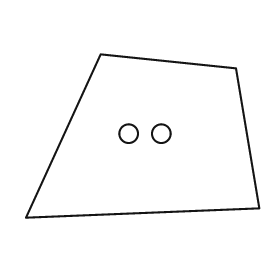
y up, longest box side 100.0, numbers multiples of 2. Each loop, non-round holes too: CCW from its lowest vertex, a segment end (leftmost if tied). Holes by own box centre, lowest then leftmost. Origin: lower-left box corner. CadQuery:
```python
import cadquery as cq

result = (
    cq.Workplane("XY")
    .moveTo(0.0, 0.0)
    .lineTo(100.0, 4.0)
    .lineTo(90.0, 64.0)
    .lineTo(32.0, 70.0)
    .close()
    .moveTo(44.0, 36.0)
    .circle(4.0)
    .moveTo(58.0, 36.0)
    .circle(4.0)
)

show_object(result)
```